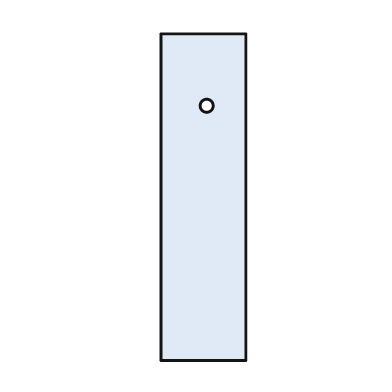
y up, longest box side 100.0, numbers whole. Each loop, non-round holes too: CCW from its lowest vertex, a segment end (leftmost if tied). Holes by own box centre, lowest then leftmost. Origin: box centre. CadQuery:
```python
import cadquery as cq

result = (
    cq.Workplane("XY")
    .moveTo(-13.0, -50.0)
    .lineTo(13.0, -50.0)
    .lineTo(13.0, 50.0)
    .lineTo(-13.0, 50.0)
    .close()
    .moveTo(1.0, 28.0)
    .circle(2.0)
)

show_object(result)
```